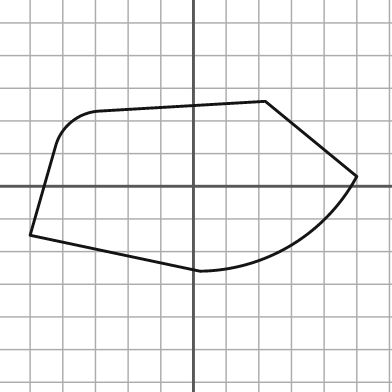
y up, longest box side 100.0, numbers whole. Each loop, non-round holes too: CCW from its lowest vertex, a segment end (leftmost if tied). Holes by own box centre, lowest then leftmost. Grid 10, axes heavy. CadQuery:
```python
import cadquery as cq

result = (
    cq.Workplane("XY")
    .moveTo(2.0, -26.0)
    .threePointArc((30.0, -18.0), (50.0, 3.0))
    .lineTo(22.0, 26.0)
    .lineTo(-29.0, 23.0)
    .threePointArc((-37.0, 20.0), (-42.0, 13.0))
    .lineTo(-50.0, -15.0)
    .close()
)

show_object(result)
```